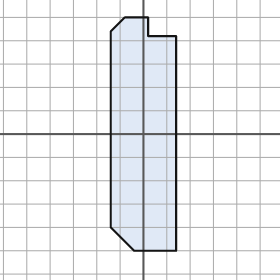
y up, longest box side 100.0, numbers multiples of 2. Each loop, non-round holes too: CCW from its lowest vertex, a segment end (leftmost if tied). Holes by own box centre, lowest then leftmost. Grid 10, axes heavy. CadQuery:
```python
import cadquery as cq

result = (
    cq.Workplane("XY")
    .moveTo(-4.0, -50.0)
    .lineTo(14.0, -50.0)
    .lineTo(14.0, 42.0)
    .lineTo(2.0, 42.0)
    .lineTo(2.0, 50.0)
    .lineTo(-8.0, 50.0)
    .lineTo(-14.0, 44.0)
    .lineTo(-14.0, -40.0)
    .close()
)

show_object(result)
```